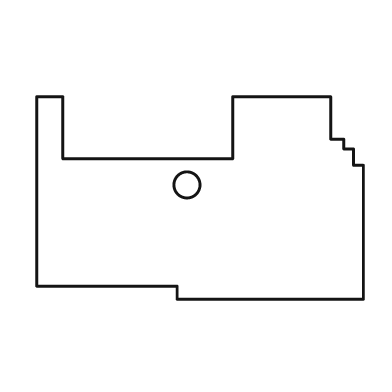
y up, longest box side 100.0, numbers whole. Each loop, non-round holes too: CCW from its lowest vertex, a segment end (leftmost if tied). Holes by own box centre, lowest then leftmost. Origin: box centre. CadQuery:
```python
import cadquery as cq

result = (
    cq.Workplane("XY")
    .moveTo(-7.0, -31.0)
    .lineTo(50.0, -31.0)
    .lineTo(50.0, 10.0)
    .lineTo(47.0, 10.0)
    .lineTo(47.0, 15.0)
    .lineTo(44.0, 15.0)
    .lineTo(44.0, 18.0)
    .lineTo(40.0, 18.0)
    .lineTo(40.0, 31.0)
    .lineTo(10.0, 31.0)
    .lineTo(10.0, 12.0)
    .lineTo(-42.0, 12.0)
    .lineTo(-42.0, 31.0)
    .lineTo(-50.0, 31.0)
    .lineTo(-50.0, -27.0)
    .lineTo(-7.0, -27.0)
    .close()
    .moveTo(-4.0, 4.0)
    .circle(4.0)
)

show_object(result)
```